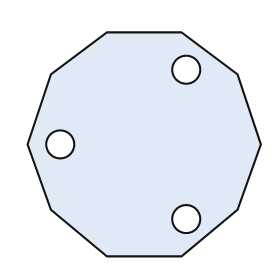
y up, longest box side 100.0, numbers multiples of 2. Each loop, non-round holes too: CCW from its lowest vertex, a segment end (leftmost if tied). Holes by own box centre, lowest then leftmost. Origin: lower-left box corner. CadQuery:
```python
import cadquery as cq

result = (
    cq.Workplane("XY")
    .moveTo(34.0, 0.0)
    .lineTo(66.0, 0.0)
    .lineTo(90.0, 20.0)
    .lineTo(100.0, 48.0)
    .lineTo(90.0, 78.0)
    .lineTo(66.0, 96.0)
    .lineTo(34.0, 96.0)
    .lineTo(10.0, 78.0)
    .lineTo(0.0, 48.0)
    .lineTo(10.0, 20.0)
    .close()
    .moveTo(68.0, 16.0)
    .circle(6.0)
    .moveTo(14.0, 48.0)
    .circle(6.0)
    .moveTo(68.0, 80.0)
    .circle(6.0)
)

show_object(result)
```